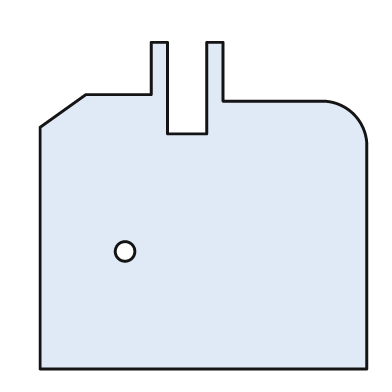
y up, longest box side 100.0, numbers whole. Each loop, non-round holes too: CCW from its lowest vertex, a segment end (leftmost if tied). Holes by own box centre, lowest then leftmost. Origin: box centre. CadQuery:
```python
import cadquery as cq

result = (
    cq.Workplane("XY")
    .moveTo(-50.0, -50.0)
    .lineTo(50.0, -50.0)
    .lineTo(50.0, 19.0)
    .threePointArc((46.0, 28.0), (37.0, 32.0))
    .lineTo(6.0, 32.0)
    .lineTo(6.0, 50.0)
    .lineTo(1.0, 50.0)
    .lineTo(1.0, 22.0)
    .lineTo(-11.0, 22.0)
    .lineTo(-11.0, 50.0)
    .lineTo(-16.0, 50.0)
    .lineTo(-16.0, 34.0)
    .lineTo(-36.0, 34.0)
    .lineTo(-50.0, 24.0)
    .close()
    .moveTo(-24.0, -14.0)
    .circle(3.0)
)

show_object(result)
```